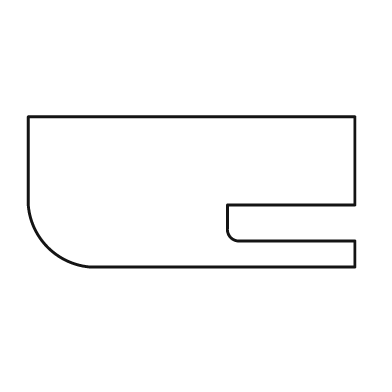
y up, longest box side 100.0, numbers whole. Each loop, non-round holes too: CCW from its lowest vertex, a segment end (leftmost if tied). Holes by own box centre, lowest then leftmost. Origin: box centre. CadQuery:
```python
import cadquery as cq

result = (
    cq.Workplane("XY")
    .moveTo(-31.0, -23.0)
    .lineTo(50.0, -23.0)
    .lineTo(50.0, -15.0)
    .lineTo(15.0, -15.0)
    .threePointArc((12.0, -14.0), (11.0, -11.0))
    .lineTo(11.0, -4.0)
    .lineTo(50.0, -4.0)
    .lineTo(50.0, 23.0)
    .lineTo(-50.0, 23.0)
    .lineTo(-50.0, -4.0)
    .threePointArc((-44.0, -17.0), (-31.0, -23.0))
    .close()
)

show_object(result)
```